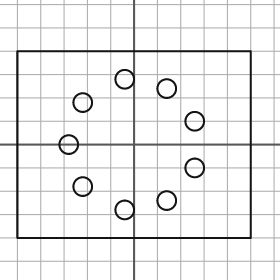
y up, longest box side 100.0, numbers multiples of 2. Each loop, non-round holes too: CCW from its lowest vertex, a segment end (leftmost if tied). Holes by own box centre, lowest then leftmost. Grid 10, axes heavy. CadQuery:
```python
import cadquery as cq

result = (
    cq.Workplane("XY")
    .moveTo(-50.0, -40.0)
    .lineTo(50.0, -40.0)
    .lineTo(50.0, 40.0)
    .lineTo(-50.0, 40.0)
    .close()
    .moveTo(-4.0, -28.0)
    .circle(4.0)
    .moveTo(14.0, -24.0)
    .circle(4.0)
    .moveTo(-22.0, -18.0)
    .circle(4.0)
    .moveTo(26.0, -10.0)
    .circle(4.0)
    .moveTo(-28.0, 0.0)
    .circle(4.0)
    .moveTo(26.0, 10.0)
    .circle(4.0)
    .moveTo(-22.0, 18.0)
    .circle(4.0)
    .moveTo(14.0, 24.0)
    .circle(4.0)
    .moveTo(-4.0, 28.0)
    .circle(4.0)
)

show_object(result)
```